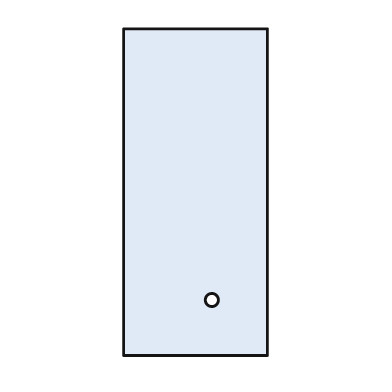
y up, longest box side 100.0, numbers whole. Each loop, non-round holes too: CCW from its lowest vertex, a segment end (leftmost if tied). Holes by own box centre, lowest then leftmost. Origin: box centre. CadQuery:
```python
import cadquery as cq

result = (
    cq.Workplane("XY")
    .moveTo(-22.0, -50.0)
    .lineTo(22.0, -50.0)
    .lineTo(22.0, 50.0)
    .lineTo(-22.0, 50.0)
    .close()
    .moveTo(5.0, -33.0)
    .circle(2.0)
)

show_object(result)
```